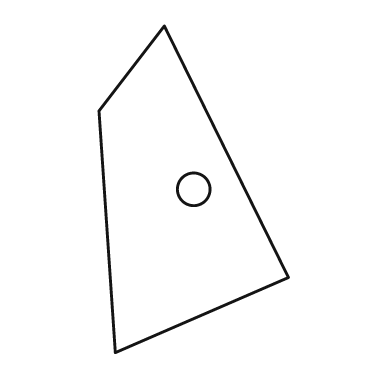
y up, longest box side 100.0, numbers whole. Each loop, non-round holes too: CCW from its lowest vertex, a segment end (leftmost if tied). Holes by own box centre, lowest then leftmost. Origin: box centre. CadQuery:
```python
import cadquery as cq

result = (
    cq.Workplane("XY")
    .moveTo(-24.0, -50.0)
    .lineTo(29.0, -27.0)
    .lineTo(-9.0, 50.0)
    .lineTo(-29.0, 24.0)
    .close()
    .moveTo(0.0, 0.0)
    .circle(5.0)
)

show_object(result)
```